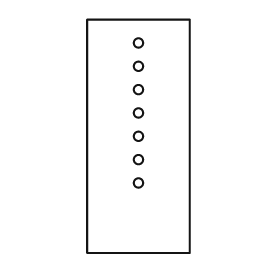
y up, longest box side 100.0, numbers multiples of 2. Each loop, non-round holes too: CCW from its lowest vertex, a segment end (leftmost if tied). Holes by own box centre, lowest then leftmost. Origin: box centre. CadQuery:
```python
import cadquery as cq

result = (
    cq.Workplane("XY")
    .moveTo(-22.0, -50.0)
    .lineTo(22.0, -50.0)
    .lineTo(22.0, 50.0)
    .lineTo(-22.0, 50.0)
    .close()
    .moveTo(0.0, -20.0)
    .circle(2.0)
    .moveTo(0.0, -10.0)
    .circle(2.0)
    .moveTo(0.0, 0.0)
    .circle(2.0)
    .moveTo(0.0, 10.0)
    .circle(2.0)
    .moveTo(0.0, 20.0)
    .circle(2.0)
    .moveTo(0.0, 30.0)
    .circle(2.0)
    .moveTo(0.0, 40.0)
    .circle(2.0)
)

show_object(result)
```